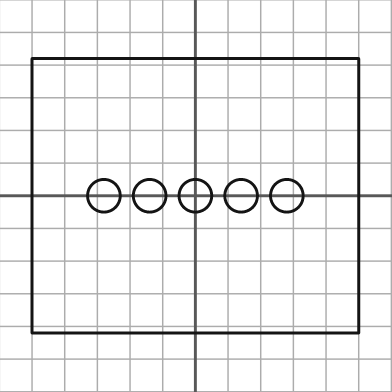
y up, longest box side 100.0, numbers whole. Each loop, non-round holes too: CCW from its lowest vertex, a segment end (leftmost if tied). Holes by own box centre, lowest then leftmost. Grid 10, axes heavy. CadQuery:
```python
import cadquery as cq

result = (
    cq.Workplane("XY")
    .moveTo(-50.0, -42.0)
    .lineTo(50.0, -42.0)
    .lineTo(50.0, 42.0)
    .lineTo(-50.0, 42.0)
    .close()
    .moveTo(-28.0, 0.0)
    .circle(5.0)
    .moveTo(-14.0, 0.0)
    .circle(5.0)
    .moveTo(0.0, 0.0)
    .circle(5.0)
    .moveTo(14.0, 0.0)
    .circle(5.0)
    .moveTo(28.0, 0.0)
    .circle(5.0)
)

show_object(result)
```